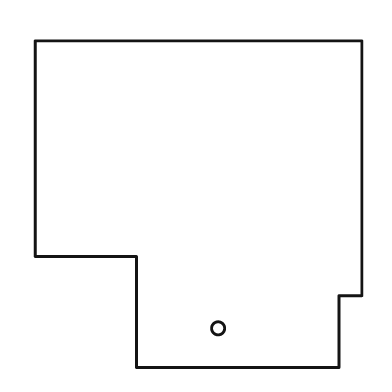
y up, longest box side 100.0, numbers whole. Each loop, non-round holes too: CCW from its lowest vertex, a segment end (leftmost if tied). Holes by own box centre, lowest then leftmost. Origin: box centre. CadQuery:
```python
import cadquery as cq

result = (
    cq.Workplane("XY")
    .moveTo(-19.0, -50.0)
    .lineTo(43.0, -50.0)
    .lineTo(43.0, -28.0)
    .lineTo(50.0, -28.0)
    .lineTo(50.0, 50.0)
    .lineTo(-50.0, 50.0)
    .lineTo(-50.0, -16.0)
    .lineTo(-19.0, -16.0)
    .close()
    .moveTo(6.0, -38.0)
    .circle(2.0)
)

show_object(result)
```